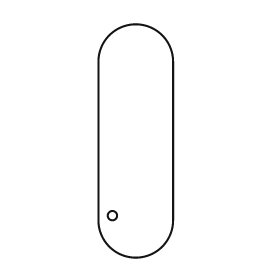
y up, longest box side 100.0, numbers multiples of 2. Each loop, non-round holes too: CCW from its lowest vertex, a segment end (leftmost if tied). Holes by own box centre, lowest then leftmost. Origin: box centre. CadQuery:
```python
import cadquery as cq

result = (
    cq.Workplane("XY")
    .moveTo(-16.0, -34.0)
    .threePointArc((0.0, -50.0), (16.0, -34.0))
    .lineTo(16.0, 34.0)
    .threePointArc((0.0, 50.0), (-16.0, 34.0))
    .close()
    .moveTo(-10.0, -32.0)
    .circle(2.0)
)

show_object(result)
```